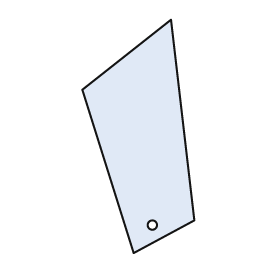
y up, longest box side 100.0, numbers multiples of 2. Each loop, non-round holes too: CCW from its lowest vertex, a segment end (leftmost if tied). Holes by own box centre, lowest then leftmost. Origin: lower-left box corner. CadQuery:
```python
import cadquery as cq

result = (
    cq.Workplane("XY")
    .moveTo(22.0, 0.0)
    .lineTo(48.0, 14.0)
    .lineTo(38.0, 100.0)
    .lineTo(0.0, 70.0)
    .close()
    .moveTo(30.0, 12.0)
    .circle(2.0)
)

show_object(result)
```